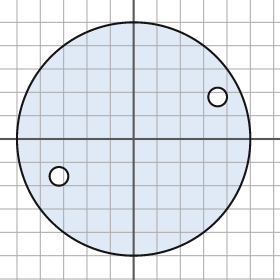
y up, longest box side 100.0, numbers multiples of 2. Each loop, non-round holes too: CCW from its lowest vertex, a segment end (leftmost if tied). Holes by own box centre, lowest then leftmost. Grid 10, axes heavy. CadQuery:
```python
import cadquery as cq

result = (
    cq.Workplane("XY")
    .moveTo(0.0, 0.0)
    .circle(50.0)
    .moveTo(-32.0, -16.0)
    .circle(4.0)
    .moveTo(36.0, 18.0)
    .circle(4.0)
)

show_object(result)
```